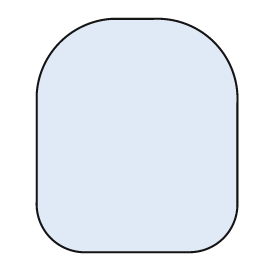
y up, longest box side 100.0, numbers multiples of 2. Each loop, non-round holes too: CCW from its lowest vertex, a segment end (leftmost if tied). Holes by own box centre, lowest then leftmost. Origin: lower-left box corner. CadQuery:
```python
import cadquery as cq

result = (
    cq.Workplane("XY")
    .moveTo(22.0, 0.0)
    .lineTo(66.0, 0.0)
    .threePointArc((80.0, 6.0), (86.0, 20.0))
    .lineTo(86.0, 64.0)
    .threePointArc((76.0, 90.0), (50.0, 100.0))
    .lineTo(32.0, 100.0)
    .threePointArc((10.0, 90.0), (0.0, 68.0))
    .lineTo(0.0, 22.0)
    .threePointArc((6.0, 6.0), (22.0, 0.0))
    .close()
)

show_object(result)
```